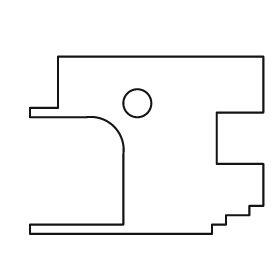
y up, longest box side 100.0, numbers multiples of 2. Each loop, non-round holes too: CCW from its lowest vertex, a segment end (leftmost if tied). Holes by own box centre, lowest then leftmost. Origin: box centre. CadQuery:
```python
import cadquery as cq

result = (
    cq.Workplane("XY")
    .moveTo(-50.0, -38.0)
    .lineTo(28.0, -38.0)
    .lineTo(28.0, -34.0)
    .lineTo(34.0, -34.0)
    .lineTo(34.0, -30.0)
    .lineTo(44.0, -30.0)
    .lineTo(44.0, -26.0)
    .lineTo(50.0, -26.0)
    .lineTo(50.0, -8.0)
    .lineTo(30.0, -8.0)
    .lineTo(30.0, 14.0)
    .lineTo(50.0, 14.0)
    .lineTo(50.0, 38.0)
    .lineTo(-38.0, 38.0)
    .lineTo(-38.0, 16.0)
    .lineTo(-50.0, 16.0)
    .lineTo(-50.0, 12.0)
    .lineTo(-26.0, 12.0)
    .threePointArc((-14.0, 8.0), (-10.0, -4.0))
    .lineTo(-10.0, -34.0)
    .lineTo(-50.0, -34.0)
    .close()
    .moveTo(-4.0, 18.0)
    .circle(6.0)
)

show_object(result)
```